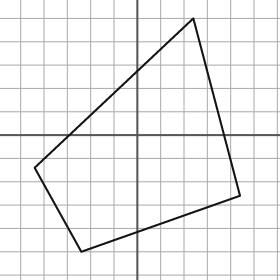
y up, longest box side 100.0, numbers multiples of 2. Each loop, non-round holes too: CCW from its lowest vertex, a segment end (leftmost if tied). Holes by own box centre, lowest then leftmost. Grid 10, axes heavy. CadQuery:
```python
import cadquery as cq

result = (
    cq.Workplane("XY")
    .moveTo(-24.0, -50.0)
    .lineTo(44.0, -26.0)
    .lineTo(24.0, 50.0)
    .lineTo(-44.0, -14.0)
    .close()
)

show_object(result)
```